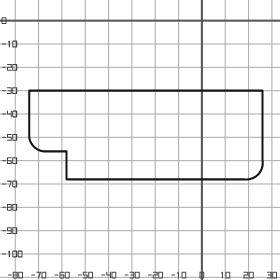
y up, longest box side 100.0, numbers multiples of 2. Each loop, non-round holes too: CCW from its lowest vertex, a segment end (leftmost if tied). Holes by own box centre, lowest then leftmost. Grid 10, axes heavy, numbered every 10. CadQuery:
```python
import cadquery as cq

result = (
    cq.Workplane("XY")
    .moveTo(-58.0, -68.0)
    .lineTo(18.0, -68.0)
    .threePointArc((24.0, -66.0), (26.0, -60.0))
    .lineTo(26.0, -30.0)
    .lineTo(-74.0, -30.0)
    .lineTo(-74.0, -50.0)
    .threePointArc((-72.0, -54.0), (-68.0, -56.0))
    .lineTo(-58.0, -56.0)
    .close()
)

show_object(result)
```